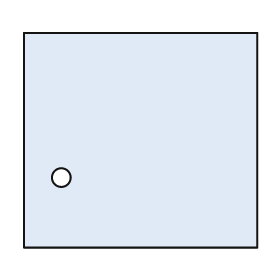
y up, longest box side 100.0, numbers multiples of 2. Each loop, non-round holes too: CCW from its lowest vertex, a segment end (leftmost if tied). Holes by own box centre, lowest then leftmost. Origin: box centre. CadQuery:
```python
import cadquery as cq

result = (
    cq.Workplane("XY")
    .moveTo(-50.0, -46.0)
    .lineTo(50.0, -46.0)
    .lineTo(50.0, 46.0)
    .lineTo(-50.0, 46.0)
    .close()
    .moveTo(-34.0, -16.0)
    .circle(4.0)
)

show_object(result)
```